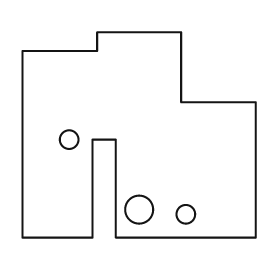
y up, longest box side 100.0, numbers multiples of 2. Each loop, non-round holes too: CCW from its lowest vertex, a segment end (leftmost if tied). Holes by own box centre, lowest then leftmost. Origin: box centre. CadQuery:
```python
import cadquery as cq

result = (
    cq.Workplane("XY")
    .moveTo(-50.0, -44.0)
    .lineTo(-20.0, -44.0)
    .lineTo(-20.0, -2.0)
    .lineTo(-10.0, -2.0)
    .lineTo(-10.0, -44.0)
    .lineTo(50.0, -44.0)
    .lineTo(50.0, 14.0)
    .lineTo(18.0, 14.0)
    .lineTo(18.0, 44.0)
    .lineTo(-18.0, 44.0)
    .lineTo(-18.0, 36.0)
    .lineTo(-50.0, 36.0)
    .close()
    .moveTo(20.0, -34.0)
    .circle(4.0)
    .moveTo(0.0, -32.0)
    .circle(6.0)
    .moveTo(-30.0, -2.0)
    .circle(4.0)
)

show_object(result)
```